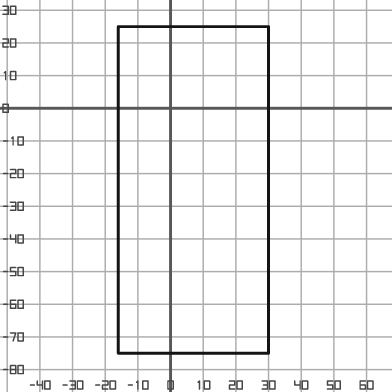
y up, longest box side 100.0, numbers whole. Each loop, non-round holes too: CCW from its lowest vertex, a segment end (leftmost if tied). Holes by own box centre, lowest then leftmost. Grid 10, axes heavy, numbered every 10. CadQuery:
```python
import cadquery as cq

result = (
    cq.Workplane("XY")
    .moveTo(-16.0, -75.0)
    .lineTo(30.0, -75.0)
    .lineTo(30.0, 25.0)
    .lineTo(-16.0, 25.0)
    .close()
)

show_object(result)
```